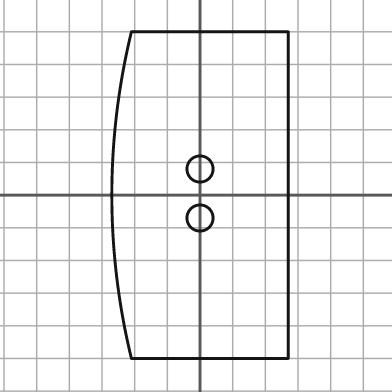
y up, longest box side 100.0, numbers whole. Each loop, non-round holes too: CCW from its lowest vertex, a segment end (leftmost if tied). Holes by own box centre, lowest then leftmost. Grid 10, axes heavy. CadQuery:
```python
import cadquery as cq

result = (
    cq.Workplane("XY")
    .moveTo(-21.0, -50.0)
    .lineTo(27.0, -50.0)
    .lineTo(27.0, 50.0)
    .lineTo(-21.0, 50.0)
    .threePointArc((-27.0, 0.0), (-21.0, -50.0))
    .close()
    .moveTo(0.0, -7.0)
    .circle(4.0)
    .moveTo(0.0, 8.0)
    .circle(4.0)
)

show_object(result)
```